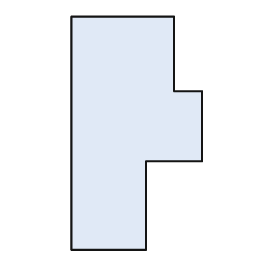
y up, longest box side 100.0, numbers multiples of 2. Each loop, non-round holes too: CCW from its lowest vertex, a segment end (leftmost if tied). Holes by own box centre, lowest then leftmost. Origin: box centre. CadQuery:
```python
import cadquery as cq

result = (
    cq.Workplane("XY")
    .moveTo(-28.0, -50.0)
    .lineTo(4.0, -50.0)
    .lineTo(4.0, -12.0)
    .lineTo(28.0, -12.0)
    .lineTo(28.0, 18.0)
    .lineTo(16.0, 18.0)
    .lineTo(16.0, 50.0)
    .lineTo(-28.0, 50.0)
    .close()
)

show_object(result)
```